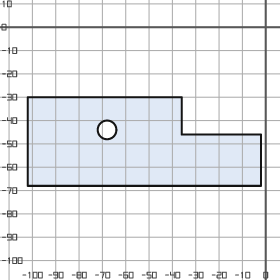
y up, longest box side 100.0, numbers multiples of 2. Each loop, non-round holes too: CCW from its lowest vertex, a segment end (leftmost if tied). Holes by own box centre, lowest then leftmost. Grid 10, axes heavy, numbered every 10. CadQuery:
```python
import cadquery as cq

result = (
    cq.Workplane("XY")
    .moveTo(-102.0, -68.0)
    .lineTo(-2.0, -68.0)
    .lineTo(-2.0, -46.0)
    .lineTo(-36.0, -46.0)
    .lineTo(-36.0, -30.0)
    .lineTo(-102.0, -30.0)
    .close()
    .moveTo(-68.0, -44.0)
    .circle(4.0)
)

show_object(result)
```